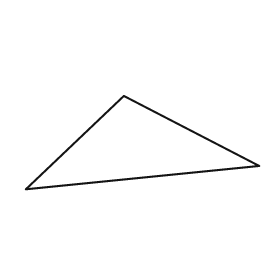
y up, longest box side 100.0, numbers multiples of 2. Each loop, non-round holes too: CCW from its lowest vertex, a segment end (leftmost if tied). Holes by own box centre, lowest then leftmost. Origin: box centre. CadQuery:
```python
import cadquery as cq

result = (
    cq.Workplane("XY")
    .moveTo(-50.0, -20.0)
    .lineTo(50.0, -10.0)
    .lineTo(-8.0, 20.0)
    .close()
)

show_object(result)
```